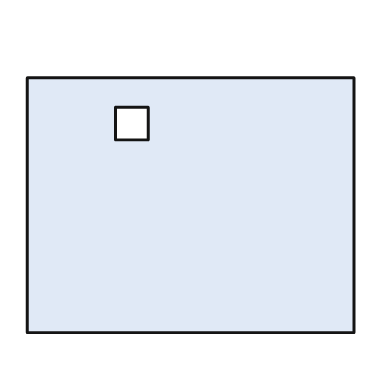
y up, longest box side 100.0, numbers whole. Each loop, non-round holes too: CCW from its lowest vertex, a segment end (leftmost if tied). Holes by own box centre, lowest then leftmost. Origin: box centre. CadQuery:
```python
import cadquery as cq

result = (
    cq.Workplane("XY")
    .moveTo(-50.0, -39.0)
    .lineTo(50.0, -39.0)
    .lineTo(50.0, 39.0)
    .lineTo(-50.0, 39.0)
    .close()
    .moveTo(-23.0, 20.0)
    .lineTo(-13.0, 20.0)
    .lineTo(-13.0, 30.0)
    .lineTo(-23.0, 30.0)
    .close()
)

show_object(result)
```